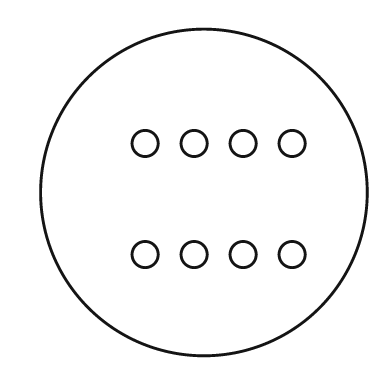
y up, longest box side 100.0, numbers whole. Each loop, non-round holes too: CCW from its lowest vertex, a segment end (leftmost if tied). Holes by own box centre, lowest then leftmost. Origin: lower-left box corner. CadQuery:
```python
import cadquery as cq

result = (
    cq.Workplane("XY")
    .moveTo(50.0, 50.0)
    .circle(50.0)
    .moveTo(32.0, 31.0)
    .circle(4.0)
    .moveTo(47.0, 31.0)
    .circle(4.0)
    .moveTo(62.0, 31.0)
    .circle(4.0)
    .moveTo(77.0, 31.0)
    .circle(4.0)
    .moveTo(32.0, 65.0)
    .circle(4.0)
    .moveTo(47.0, 65.0)
    .circle(4.0)
    .moveTo(62.0, 65.0)
    .circle(4.0)
    .moveTo(77.0, 65.0)
    .circle(4.0)
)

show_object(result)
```